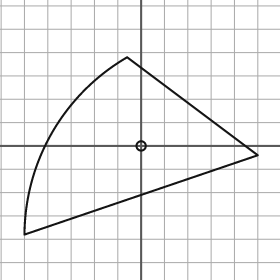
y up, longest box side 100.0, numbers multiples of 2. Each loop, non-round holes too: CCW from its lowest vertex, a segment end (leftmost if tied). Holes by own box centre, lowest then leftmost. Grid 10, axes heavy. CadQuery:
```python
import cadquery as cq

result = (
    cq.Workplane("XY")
    .moveTo(-50.0, -38.0)
    .lineTo(50.0, -4.0)
    .lineTo(-6.0, 38.0)
    .threePointArc((-38.0, 6.0), (-50.0, -38.0))
    .close()
    .moveTo(0.0, 0.0)
    .circle(2.0)
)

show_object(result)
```